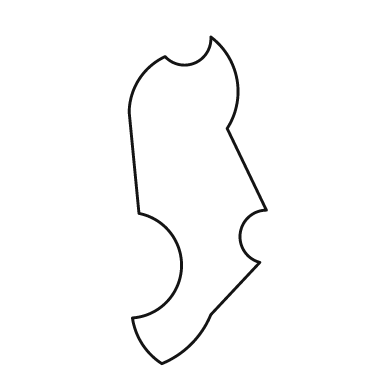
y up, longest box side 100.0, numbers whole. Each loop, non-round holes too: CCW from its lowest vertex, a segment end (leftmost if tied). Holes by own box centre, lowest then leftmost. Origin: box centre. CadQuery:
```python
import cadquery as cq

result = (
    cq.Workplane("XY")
    .moveTo(-11.0, -50.0)
    .threePointArc((-2.0, -44.0), (4.0, -35.0))
    .lineTo(19.0, -19.0)
    .threePointArc((13.0, -10.0), (21.0, -3.0))
    .lineTo(9.0, 22.0)
    .threePointArc((12.0, 37.0), (4.0, 50.0))
    .threePointArc((-1.0, 42.0), (-10.0, 44.0))
    .threePointArc((-18.0, 37.0), (-21.0, 27.0))
    .lineTo(-18.0, -4.0)
    .threePointArc((-5.0, -21.0), (-20.0, -36.0))
    .threePointArc((-17.0, -44.0), (-11.0, -50.0))
    .close()
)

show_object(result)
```